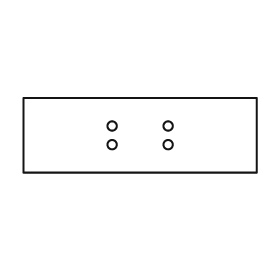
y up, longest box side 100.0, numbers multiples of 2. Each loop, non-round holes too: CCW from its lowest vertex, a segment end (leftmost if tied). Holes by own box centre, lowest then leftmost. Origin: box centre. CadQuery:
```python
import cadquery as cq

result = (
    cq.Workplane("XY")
    .moveTo(-50.0, -16.0)
    .lineTo(50.0, -16.0)
    .lineTo(50.0, 16.0)
    .lineTo(-50.0, 16.0)
    .close()
    .moveTo(-12.0, -4.0)
    .circle(2.0)
    .moveTo(12.0, -4.0)
    .circle(2.0)
    .moveTo(-12.0, 4.0)
    .circle(2.0)
    .moveTo(12.0, 4.0)
    .circle(2.0)
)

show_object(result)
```